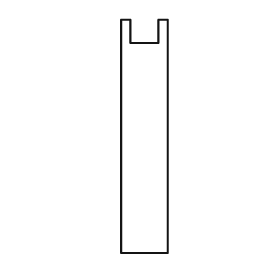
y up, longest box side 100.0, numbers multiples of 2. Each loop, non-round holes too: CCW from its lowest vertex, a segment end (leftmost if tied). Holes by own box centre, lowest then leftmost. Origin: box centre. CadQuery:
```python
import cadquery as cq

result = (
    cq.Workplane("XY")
    .moveTo(-10.0, -50.0)
    .lineTo(10.0, -50.0)
    .lineTo(10.0, 50.0)
    .lineTo(6.0, 50.0)
    .lineTo(6.0, 40.0)
    .lineTo(-6.0, 40.0)
    .lineTo(-6.0, 50.0)
    .lineTo(-10.0, 50.0)
    .close()
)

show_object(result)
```